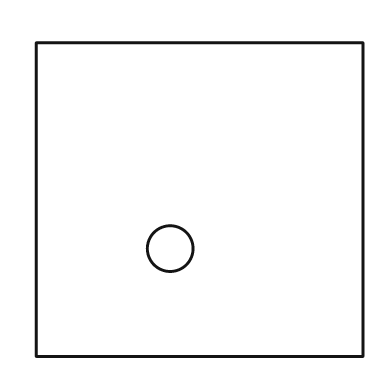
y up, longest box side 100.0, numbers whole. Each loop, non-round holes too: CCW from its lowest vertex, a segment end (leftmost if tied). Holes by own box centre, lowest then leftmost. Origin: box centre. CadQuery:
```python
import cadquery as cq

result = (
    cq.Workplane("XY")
    .moveTo(-50.0, -48.0)
    .lineTo(50.0, -48.0)
    .lineTo(50.0, 48.0)
    .lineTo(-50.0, 48.0)
    .close()
    .moveTo(-9.0, -15.0)
    .circle(7.0)
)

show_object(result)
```